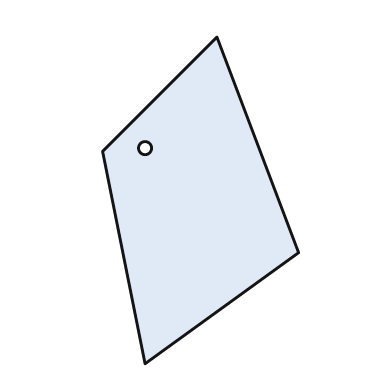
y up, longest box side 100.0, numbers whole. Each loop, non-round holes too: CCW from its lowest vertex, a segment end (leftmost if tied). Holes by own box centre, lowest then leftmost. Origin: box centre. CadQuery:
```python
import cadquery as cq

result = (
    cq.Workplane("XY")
    .moveTo(-17.0, -50.0)
    .lineTo(30.0, -16.0)
    .lineTo(5.0, 50.0)
    .lineTo(-30.0, 15.0)
    .close()
    .moveTo(-17.0, 16.0)
    .circle(2.0)
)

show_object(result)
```